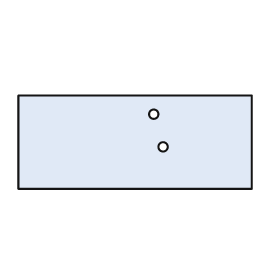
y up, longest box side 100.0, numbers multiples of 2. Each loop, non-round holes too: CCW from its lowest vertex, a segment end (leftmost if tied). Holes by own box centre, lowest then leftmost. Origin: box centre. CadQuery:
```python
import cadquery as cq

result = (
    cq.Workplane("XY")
    .moveTo(-50.0, -20.0)
    .lineTo(50.0, -20.0)
    .lineTo(50.0, 20.0)
    .lineTo(-50.0, 20.0)
    .close()
    .moveTo(12.0, -2.0)
    .circle(2.0)
    .moveTo(8.0, 12.0)
    .circle(2.0)
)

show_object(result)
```